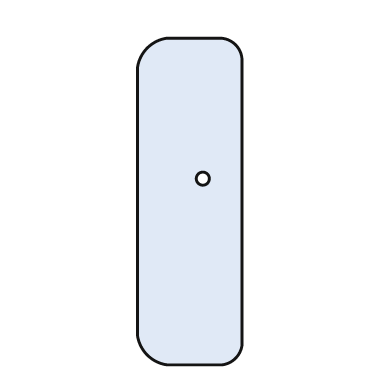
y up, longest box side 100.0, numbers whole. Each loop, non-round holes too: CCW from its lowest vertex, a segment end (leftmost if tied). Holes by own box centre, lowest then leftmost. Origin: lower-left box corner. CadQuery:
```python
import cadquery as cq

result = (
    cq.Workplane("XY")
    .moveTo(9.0, 0.0)
    .lineTo(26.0, 0.0)
    .threePointArc((30.0, 2.0), (32.0, 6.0))
    .lineTo(32.0, 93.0)
    .threePointArc((30.0, 98.0), (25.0, 100.0))
    .lineTo(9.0, 100.0)
    .threePointArc((3.0, 97.0), (0.0, 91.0))
    .lineTo(0.0, 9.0)
    .threePointArc((3.0, 3.0), (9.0, 0.0))
    .close()
    .moveTo(20.0, 57.0)
    .circle(2.0)
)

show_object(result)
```